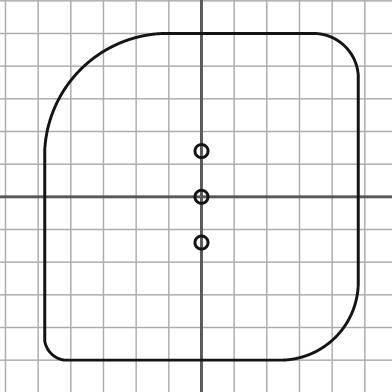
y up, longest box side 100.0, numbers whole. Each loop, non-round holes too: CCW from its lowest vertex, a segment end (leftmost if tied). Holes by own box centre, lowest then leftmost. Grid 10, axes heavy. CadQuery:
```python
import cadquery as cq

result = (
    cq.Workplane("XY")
    .moveTo(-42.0, -50.0)
    .lineTo(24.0, -50.0)
    .threePointArc((41.0, -43.0), (48.0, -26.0))
    .lineTo(48.0, 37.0)
    .threePointArc((44.0, 46.0), (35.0, 50.0))
    .lineTo(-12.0, 50.0)
    .threePointArc((-37.0, 39.0), (-48.0, 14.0))
    .lineTo(-48.0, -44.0)
    .threePointArc((-46.0, -48.0), (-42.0, -50.0))
    .close()
    .moveTo(0.0, -14.0)
    .circle(2.0)
    .moveTo(0.0, 0.0)
    .circle(2.0)
    .moveTo(0.0, 14.0)
    .circle(2.0)
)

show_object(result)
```